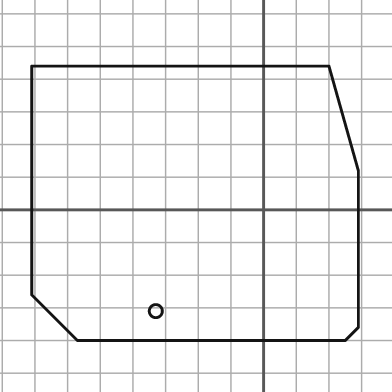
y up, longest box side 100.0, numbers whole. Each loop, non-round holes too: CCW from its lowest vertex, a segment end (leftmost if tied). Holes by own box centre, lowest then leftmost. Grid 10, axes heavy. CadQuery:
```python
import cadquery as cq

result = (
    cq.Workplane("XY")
    .moveTo(-57.0, -40.0)
    .lineTo(25.0, -40.0)
    .lineTo(29.0, -36.0)
    .lineTo(29.0, 12.0)
    .lineTo(20.0, 44.0)
    .lineTo(-71.0, 44.0)
    .lineTo(-71.0, -26.0)
    .close()
    .moveTo(-33.0, -31.0)
    .circle(2.0)
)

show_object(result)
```